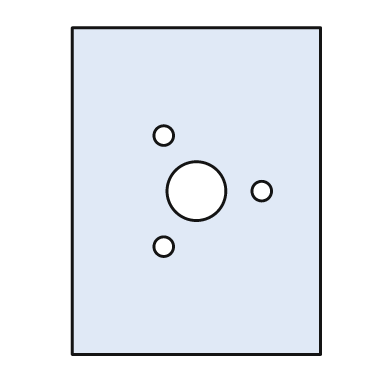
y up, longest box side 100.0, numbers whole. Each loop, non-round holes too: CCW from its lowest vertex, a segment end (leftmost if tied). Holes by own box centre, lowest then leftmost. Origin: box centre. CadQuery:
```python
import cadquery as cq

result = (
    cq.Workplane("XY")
    .moveTo(-38.0, -50.0)
    .lineTo(38.0, -50.0)
    .lineTo(38.0, 50.0)
    .lineTo(-38.0, 50.0)
    .close()
    .moveTo(-10.0, -17.0)
    .circle(3.0)
    .moveTo(0.0, 0.0)
    .circle(9.0)
    .moveTo(20.0, 0.0)
    .circle(3.0)
    .moveTo(-10.0, 17.0)
    .circle(3.0)
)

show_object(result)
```